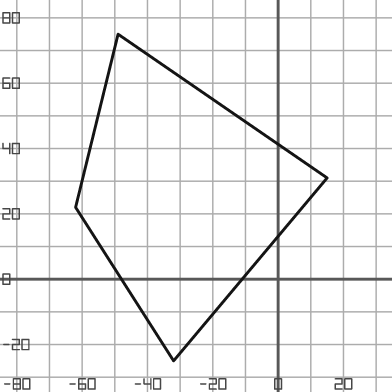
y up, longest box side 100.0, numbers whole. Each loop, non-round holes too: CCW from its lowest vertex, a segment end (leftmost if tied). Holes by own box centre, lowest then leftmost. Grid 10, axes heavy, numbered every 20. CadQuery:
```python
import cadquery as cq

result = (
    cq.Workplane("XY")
    .moveTo(-32.0, -25.0)
    .lineTo(15.0, 31.0)
    .lineTo(-49.0, 75.0)
    .lineTo(-62.0, 22.0)
    .close()
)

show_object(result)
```